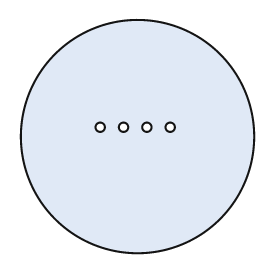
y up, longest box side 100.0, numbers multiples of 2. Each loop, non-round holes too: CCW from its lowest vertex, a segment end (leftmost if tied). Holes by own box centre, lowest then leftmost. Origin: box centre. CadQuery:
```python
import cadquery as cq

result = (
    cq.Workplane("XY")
    .moveTo(0.0, 0.0)
    .circle(50.0)
    .moveTo(-16.0, 4.0)
    .circle(2.0)
    .moveTo(-6.0, 4.0)
    .circle(2.0)
    .moveTo(4.0, 4.0)
    .circle(2.0)
    .moveTo(14.0, 4.0)
    .circle(2.0)
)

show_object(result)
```